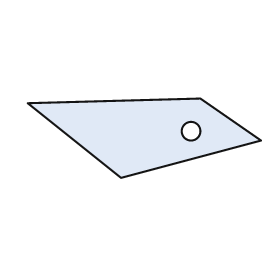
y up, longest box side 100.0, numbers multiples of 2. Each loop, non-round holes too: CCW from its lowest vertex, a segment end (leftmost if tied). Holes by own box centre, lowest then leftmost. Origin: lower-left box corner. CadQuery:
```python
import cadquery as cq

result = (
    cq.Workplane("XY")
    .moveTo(40.0, 0.0)
    .lineTo(100.0, 16.0)
    .lineTo(74.0, 34.0)
    .lineTo(0.0, 32.0)
    .close()
    .moveTo(70.0, 20.0)
    .circle(4.0)
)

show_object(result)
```